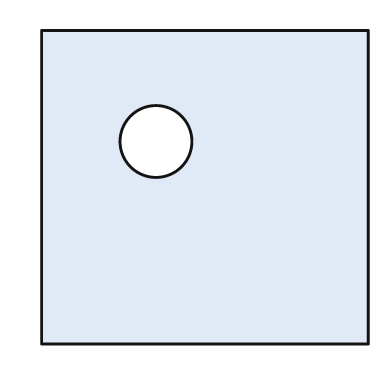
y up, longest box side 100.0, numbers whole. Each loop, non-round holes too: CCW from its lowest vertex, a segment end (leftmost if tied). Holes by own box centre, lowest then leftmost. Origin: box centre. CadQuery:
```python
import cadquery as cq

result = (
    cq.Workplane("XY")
    .moveTo(-50.0, -48.0)
    .lineTo(50.0, -48.0)
    .lineTo(50.0, 48.0)
    .lineTo(-50.0, 48.0)
    .close()
    .moveTo(-15.0, 14.0)
    .circle(11.0)
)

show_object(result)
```